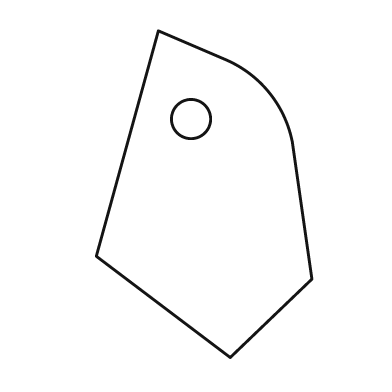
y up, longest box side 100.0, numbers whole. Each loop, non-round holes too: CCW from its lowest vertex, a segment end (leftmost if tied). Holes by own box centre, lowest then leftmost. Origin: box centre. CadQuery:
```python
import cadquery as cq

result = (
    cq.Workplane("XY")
    .moveTo(8.0, -50.0)
    .lineTo(33.0, -26.0)
    .lineTo(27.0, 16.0)
    .threePointArc((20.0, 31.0), (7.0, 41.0))
    .lineTo(-14.0, 50.0)
    .lineTo(-33.0, -19.0)
    .close()
    .moveTo(-4.0, 23.0)
    .circle(6.0)
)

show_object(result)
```